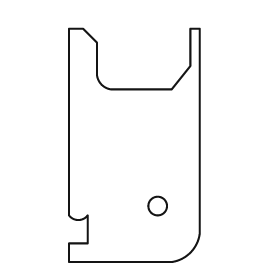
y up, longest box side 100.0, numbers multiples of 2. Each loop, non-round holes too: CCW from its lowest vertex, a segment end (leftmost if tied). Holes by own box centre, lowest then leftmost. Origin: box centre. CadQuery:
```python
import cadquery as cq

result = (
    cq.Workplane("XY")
    .moveTo(-28.0, -50.0)
    .lineTo(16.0, -50.0)
    .threePointArc((24.0, -46.0), (28.0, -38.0))
    .lineTo(28.0, 50.0)
    .lineTo(24.0, 50.0)
    .lineTo(24.0, 34.0)
    .lineTo(16.0, 24.0)
    .lineTo(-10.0, 24.0)
    .threePointArc((-14.0, 26.0), (-16.0, 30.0))
    .lineTo(-16.0, 44.0)
    .lineTo(-22.0, 50.0)
    .lineTo(-28.0, 50.0)
    .lineTo(-28.0, -30.0)
    .threePointArc((-24.0, -32.0), (-20.0, -30.0))
    .lineTo(-20.0, -42.0)
    .lineTo(-28.0, -42.0)
    .close()
    .moveTo(10.0, -26.0)
    .circle(4.0)
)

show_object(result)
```